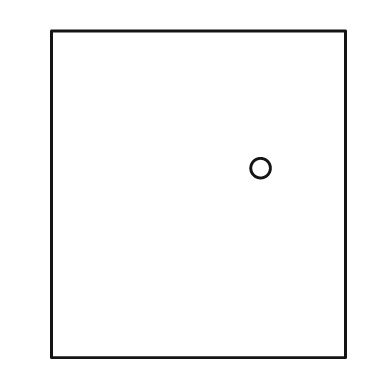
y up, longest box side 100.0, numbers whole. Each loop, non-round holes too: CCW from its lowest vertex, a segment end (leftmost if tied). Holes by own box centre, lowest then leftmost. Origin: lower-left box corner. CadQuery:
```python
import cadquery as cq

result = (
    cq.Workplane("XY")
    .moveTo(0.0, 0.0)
    .lineTo(90.0, 0.0)
    .lineTo(90.0, 100.0)
    .lineTo(0.0, 100.0)
    .close()
    .moveTo(64.0, 58.0)
    .circle(3.0)
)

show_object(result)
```